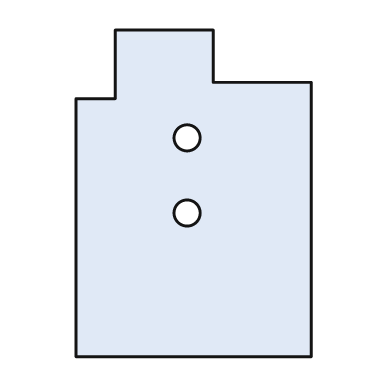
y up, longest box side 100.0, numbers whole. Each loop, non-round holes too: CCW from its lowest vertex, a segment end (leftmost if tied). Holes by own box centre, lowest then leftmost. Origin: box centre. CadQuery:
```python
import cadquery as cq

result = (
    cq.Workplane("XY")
    .moveTo(-36.0, -50.0)
    .lineTo(36.0, -50.0)
    .lineTo(36.0, 34.0)
    .lineTo(6.0, 34.0)
    .lineTo(6.0, 50.0)
    .lineTo(-24.0, 50.0)
    .lineTo(-24.0, 29.0)
    .lineTo(-36.0, 29.0)
    .close()
    .moveTo(-2.0, -6.0)
    .circle(4.0)
    .moveTo(-2.0, 17.0)
    .circle(4.0)
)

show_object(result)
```